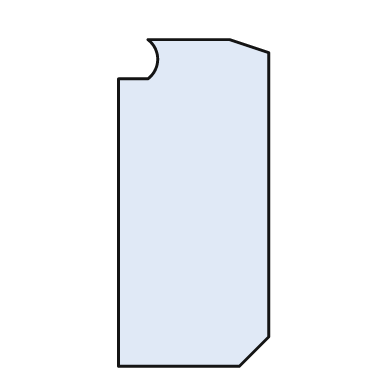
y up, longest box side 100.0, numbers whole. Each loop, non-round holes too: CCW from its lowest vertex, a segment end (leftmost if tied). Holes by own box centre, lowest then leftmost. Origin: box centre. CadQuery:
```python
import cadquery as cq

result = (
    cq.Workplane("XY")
    .moveTo(-23.0, -50.0)
    .lineTo(14.0, -50.0)
    .lineTo(23.0, -41.0)
    .lineTo(23.0, 46.0)
    .lineTo(11.0, 50.0)
    .lineTo(-14.0, 50.0)
    .threePointArc((-11.0, 44.0), (-14.0, 38.0))
    .lineTo(-23.0, 38.0)
    .close()
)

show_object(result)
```